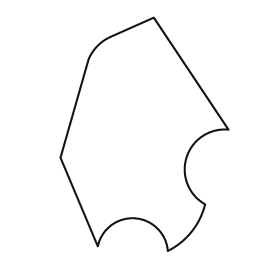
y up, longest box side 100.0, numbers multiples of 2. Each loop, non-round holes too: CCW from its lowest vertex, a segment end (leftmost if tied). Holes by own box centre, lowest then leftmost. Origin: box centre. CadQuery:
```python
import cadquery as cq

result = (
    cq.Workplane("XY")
    .moveTo(10.0, -50.0)
    .threePointArc((20.0, -42.0), (26.0, -30.0))
    .threePointArc((18.0, -10.0), (36.0, 2.0))
    .lineTo(4.0, 50.0)
    .lineTo(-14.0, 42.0)
    .threePointArc((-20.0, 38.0), (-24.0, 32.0))
    .lineTo(-36.0, -10.0)
    .lineTo(-20.0, -48.0)
    .threePointArc((-4.0, -36.0), (10.0, -50.0))
    .close()
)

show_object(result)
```